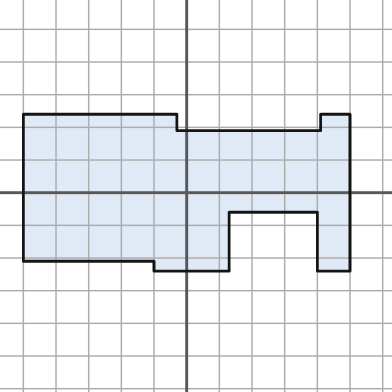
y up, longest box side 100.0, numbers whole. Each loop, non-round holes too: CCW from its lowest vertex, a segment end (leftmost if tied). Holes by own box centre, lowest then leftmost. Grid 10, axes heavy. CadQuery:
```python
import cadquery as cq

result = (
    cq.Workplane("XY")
    .moveTo(-10.0, -24.0)
    .lineTo(13.0, -24.0)
    .lineTo(13.0, -6.0)
    .lineTo(40.0, -6.0)
    .lineTo(40.0, -24.0)
    .lineTo(50.0, -24.0)
    .lineTo(50.0, 24.0)
    .lineTo(41.0, 24.0)
    .lineTo(41.0, 19.0)
    .lineTo(-3.0, 19.0)
    .lineTo(-3.0, 24.0)
    .lineTo(-50.0, 24.0)
    .lineTo(-50.0, -21.0)
    .lineTo(-10.0, -21.0)
    .close()
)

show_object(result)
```